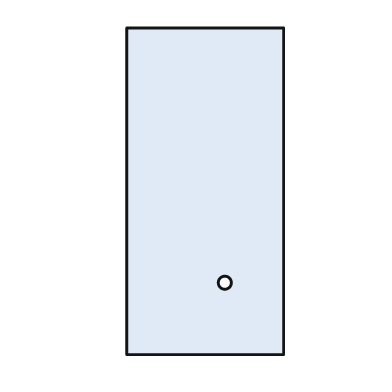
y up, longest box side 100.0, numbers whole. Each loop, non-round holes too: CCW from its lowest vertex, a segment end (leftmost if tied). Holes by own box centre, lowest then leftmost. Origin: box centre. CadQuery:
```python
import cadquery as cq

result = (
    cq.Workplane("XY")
    .moveTo(-24.0, -50.0)
    .lineTo(24.0, -50.0)
    .lineTo(24.0, 50.0)
    .lineTo(-24.0, 50.0)
    .close()
    .moveTo(6.0, -28.0)
    .circle(2.0)
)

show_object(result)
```